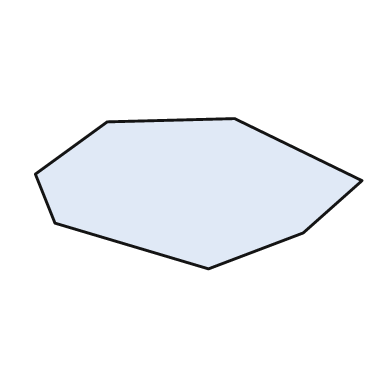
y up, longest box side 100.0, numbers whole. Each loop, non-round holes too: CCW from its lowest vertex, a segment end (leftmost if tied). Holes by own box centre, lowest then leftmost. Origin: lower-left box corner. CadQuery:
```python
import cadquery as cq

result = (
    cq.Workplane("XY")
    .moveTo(53.0, 0.0)
    .lineTo(82.0, 11.0)
    .lineTo(100.0, 27.0)
    .lineTo(61.0, 46.0)
    .lineTo(22.0, 45.0)
    .lineTo(0.0, 29.0)
    .lineTo(6.0, 14.0)
    .close()
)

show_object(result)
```